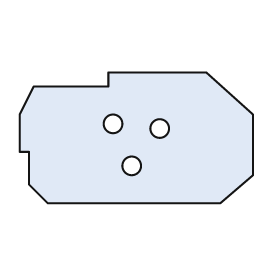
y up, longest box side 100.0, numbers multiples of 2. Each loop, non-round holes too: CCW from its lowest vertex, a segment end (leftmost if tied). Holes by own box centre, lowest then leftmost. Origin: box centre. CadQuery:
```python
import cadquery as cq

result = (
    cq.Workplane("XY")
    .moveTo(-38.0, -28.0)
    .lineTo(36.0, -28.0)
    .lineTo(50.0, -16.0)
    .lineTo(50.0, 10.0)
    .lineTo(30.0, 28.0)
    .lineTo(-12.0, 28.0)
    .lineTo(-12.0, 22.0)
    .lineTo(-44.0, 22.0)
    .lineTo(-50.0, 10.0)
    .lineTo(-50.0, -6.0)
    .lineTo(-46.0, -6.0)
    .lineTo(-46.0, -20.0)
    .close()
    .moveTo(-2.0, -12.0)
    .circle(4.0)
    .moveTo(10.0, 4.0)
    .circle(4.0)
    .moveTo(-10.0, 6.0)
    .circle(4.0)
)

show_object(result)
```